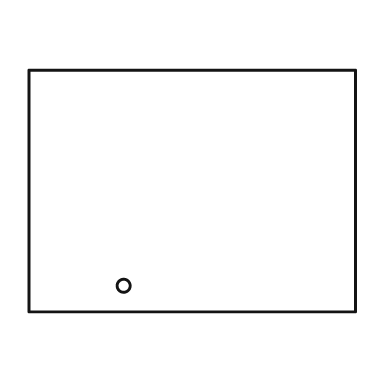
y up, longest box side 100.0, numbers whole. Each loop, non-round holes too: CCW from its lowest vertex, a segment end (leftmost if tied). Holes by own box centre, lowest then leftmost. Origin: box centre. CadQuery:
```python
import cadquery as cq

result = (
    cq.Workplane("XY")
    .moveTo(-50.0, -37.0)
    .lineTo(50.0, -37.0)
    .lineTo(50.0, 37.0)
    .lineTo(-50.0, 37.0)
    .close()
    .moveTo(-21.0, -29.0)
    .circle(2.0)
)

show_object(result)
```